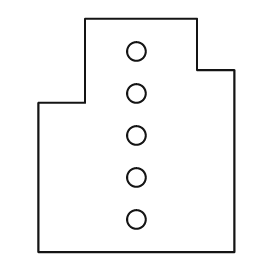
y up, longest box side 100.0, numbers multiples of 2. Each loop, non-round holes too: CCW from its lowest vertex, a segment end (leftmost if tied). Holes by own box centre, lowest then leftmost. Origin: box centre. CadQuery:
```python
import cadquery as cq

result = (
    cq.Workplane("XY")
    .moveTo(-42.0, -50.0)
    .lineTo(42.0, -50.0)
    .lineTo(42.0, 28.0)
    .lineTo(26.0, 28.0)
    .lineTo(26.0, 50.0)
    .lineTo(-22.0, 50.0)
    .lineTo(-22.0, 14.0)
    .lineTo(-42.0, 14.0)
    .close()
    .moveTo(0.0, -36.0)
    .circle(4.0)
    .moveTo(0.0, -18.0)
    .circle(4.0)
    .moveTo(0.0, 0.0)
    .circle(4.0)
    .moveTo(0.0, 18.0)
    .circle(4.0)
    .moveTo(0.0, 36.0)
    .circle(4.0)
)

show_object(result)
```